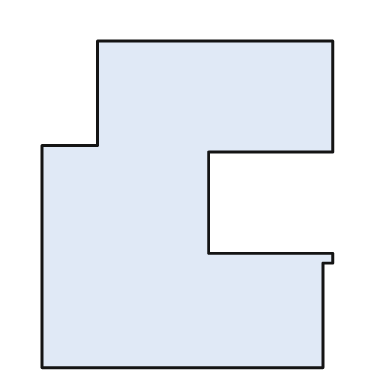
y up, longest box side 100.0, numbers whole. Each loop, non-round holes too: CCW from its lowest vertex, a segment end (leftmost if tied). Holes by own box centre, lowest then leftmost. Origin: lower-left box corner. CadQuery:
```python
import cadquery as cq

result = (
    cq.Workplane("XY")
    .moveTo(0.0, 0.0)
    .lineTo(86.0, 0.0)
    .lineTo(86.0, 32.0)
    .lineTo(89.0, 32.0)
    .lineTo(89.0, 35.0)
    .lineTo(51.0, 35.0)
    .lineTo(51.0, 66.0)
    .lineTo(89.0, 66.0)
    .lineTo(89.0, 100.0)
    .lineTo(17.0, 100.0)
    .lineTo(17.0, 68.0)
    .lineTo(0.0, 68.0)
    .close()
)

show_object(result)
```